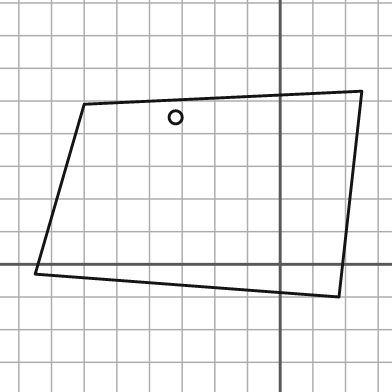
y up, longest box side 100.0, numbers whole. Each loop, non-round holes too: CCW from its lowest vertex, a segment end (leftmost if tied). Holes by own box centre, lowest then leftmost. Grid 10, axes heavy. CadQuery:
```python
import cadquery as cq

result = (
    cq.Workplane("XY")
    .moveTo(18.0, -10.0)
    .lineTo(25.0, 53.0)
    .lineTo(-60.0, 49.0)
    .lineTo(-75.0, -3.0)
    .close()
    .moveTo(-32.0, 45.0)
    .circle(2.0)
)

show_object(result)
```